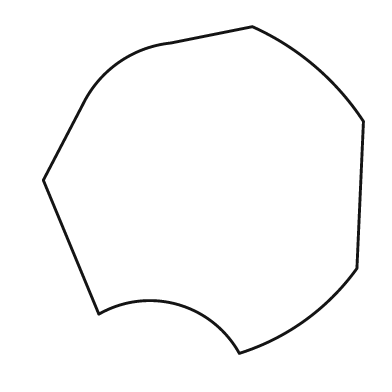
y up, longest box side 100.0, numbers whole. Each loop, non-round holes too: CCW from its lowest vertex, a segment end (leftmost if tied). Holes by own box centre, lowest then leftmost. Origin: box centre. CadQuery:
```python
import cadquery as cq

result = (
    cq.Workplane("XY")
    .moveTo(11.0, -50.0)
    .threePointArc((31.0, -40.0), (47.0, -24.0))
    .lineTo(49.0, 21.0)
    .threePointArc((34.0, 38.0), (15.0, 50.0))
    .lineTo(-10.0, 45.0)
    .threePointArc((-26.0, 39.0), (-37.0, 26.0))
    .lineTo(-49.0, 3.0)
    .lineTo(-32.0, -38.0)
    .threePointArc((-8.0, -35.0), (11.0, -50.0))
    .close()
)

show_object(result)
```